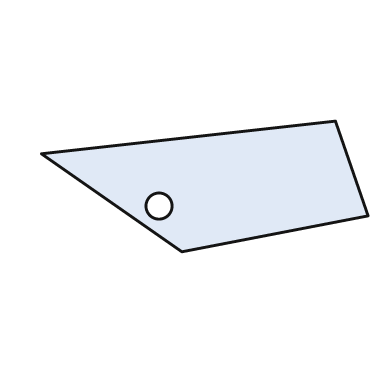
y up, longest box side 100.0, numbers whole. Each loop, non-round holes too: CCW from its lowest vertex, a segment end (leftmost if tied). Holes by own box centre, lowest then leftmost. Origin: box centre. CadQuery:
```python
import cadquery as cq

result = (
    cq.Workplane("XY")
    .moveTo(-7.0, -20.0)
    .lineTo(50.0, -9.0)
    .lineTo(40.0, 20.0)
    .lineTo(-50.0, 10.0)
    .close()
    .moveTo(-14.0, -6.0)
    .circle(4.0)
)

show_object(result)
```